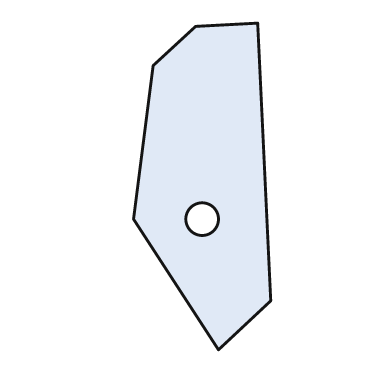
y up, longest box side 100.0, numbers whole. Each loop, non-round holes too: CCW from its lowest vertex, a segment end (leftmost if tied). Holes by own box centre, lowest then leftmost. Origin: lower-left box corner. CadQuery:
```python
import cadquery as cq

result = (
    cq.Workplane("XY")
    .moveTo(26.0, 0.0)
    .lineTo(42.0, 15.0)
    .lineTo(38.0, 100.0)
    .lineTo(19.0, 99.0)
    .lineTo(6.0, 87.0)
    .lineTo(0.0, 40.0)
    .close()
    .moveTo(21.0, 40.0)
    .circle(5.0)
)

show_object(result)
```